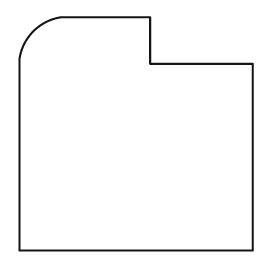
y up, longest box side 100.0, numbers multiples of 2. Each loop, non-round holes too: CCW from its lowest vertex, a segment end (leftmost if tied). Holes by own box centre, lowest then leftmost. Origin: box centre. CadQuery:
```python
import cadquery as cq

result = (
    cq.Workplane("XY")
    .moveTo(-50.0, -50.0)
    .lineTo(50.0, -50.0)
    .lineTo(50.0, 30.0)
    .lineTo(6.0, 30.0)
    .lineTo(6.0, 50.0)
    .lineTo(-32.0, 50.0)
    .threePointArc((-44.0, 44.0), (-50.0, 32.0))
    .close()
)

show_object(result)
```